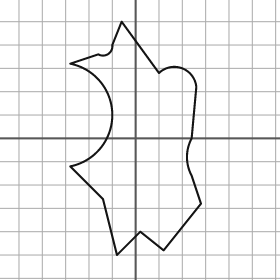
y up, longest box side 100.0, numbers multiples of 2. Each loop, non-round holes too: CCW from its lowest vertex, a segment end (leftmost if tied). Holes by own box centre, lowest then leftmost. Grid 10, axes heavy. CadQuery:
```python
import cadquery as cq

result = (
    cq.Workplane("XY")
    .moveTo(-8.0, -50.0)
    .lineTo(2.0, -40.0)
    .lineTo(12.0, -48.0)
    .lineTo(28.0, -28.0)
    .lineTo(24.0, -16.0)
    .threePointArc((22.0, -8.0), (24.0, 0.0))
    .lineTo(26.0, 22.0)
    .threePointArc((20.0, 30.0), (10.0, 28.0))
    .lineTo(-6.0, 50.0)
    .lineTo(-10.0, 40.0)
    .threePointArc((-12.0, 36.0), (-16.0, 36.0))
    .lineTo(-28.0, 32.0)
    .threePointArc((-10.0, 10.0), (-28.0, -12.0))
    .lineTo(-14.0, -26.0)
    .close()
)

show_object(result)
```